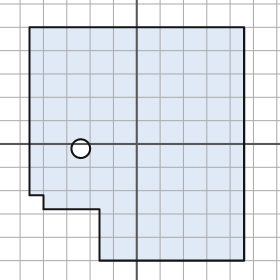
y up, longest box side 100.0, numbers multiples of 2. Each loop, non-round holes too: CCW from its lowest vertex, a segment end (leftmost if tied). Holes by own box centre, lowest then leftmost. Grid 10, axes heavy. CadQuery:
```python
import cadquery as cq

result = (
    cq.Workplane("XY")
    .moveTo(-16.0, -50.0)
    .lineTo(46.0, -50.0)
    .lineTo(46.0, 50.0)
    .lineTo(-46.0, 50.0)
    .lineTo(-46.0, -22.0)
    .lineTo(-40.0, -22.0)
    .lineTo(-40.0, -28.0)
    .lineTo(-16.0, -28.0)
    .close()
    .moveTo(-24.0, -2.0)
    .circle(4.0)
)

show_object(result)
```